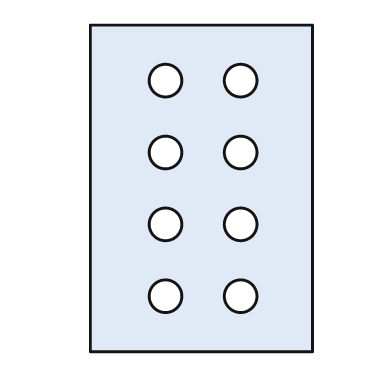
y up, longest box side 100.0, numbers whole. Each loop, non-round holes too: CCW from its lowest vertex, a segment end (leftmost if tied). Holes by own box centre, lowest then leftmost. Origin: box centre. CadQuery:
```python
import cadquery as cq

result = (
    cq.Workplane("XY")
    .moveTo(-34.0, -50.0)
    .lineTo(34.0, -50.0)
    .lineTo(34.0, 50.0)
    .lineTo(-34.0, 50.0)
    .close()
    .moveTo(-11.0, -33.0)
    .circle(5.0)
    .moveTo(12.0, -33.0)
    .circle(5.0)
    .moveTo(-11.0, -11.0)
    .circle(5.0)
    .moveTo(12.0, -11.0)
    .circle(5.0)
    .moveTo(-11.0, 11.0)
    .circle(5.0)
    .moveTo(12.0, 11.0)
    .circle(5.0)
    .moveTo(-11.0, 33.0)
    .circle(5.0)
    .moveTo(12.0, 33.0)
    .circle(5.0)
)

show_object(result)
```